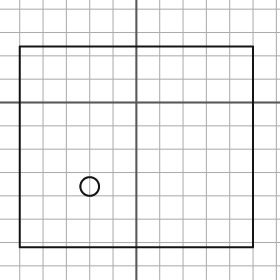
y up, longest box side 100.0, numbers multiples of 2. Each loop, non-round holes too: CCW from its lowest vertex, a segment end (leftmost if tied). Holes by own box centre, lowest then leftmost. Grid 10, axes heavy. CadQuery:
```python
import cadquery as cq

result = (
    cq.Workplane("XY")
    .moveTo(-50.0, -62.0)
    .lineTo(50.0, -62.0)
    .lineTo(50.0, 24.0)
    .lineTo(-50.0, 24.0)
    .close()
    .moveTo(-20.0, -36.0)
    .circle(4.0)
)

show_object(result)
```